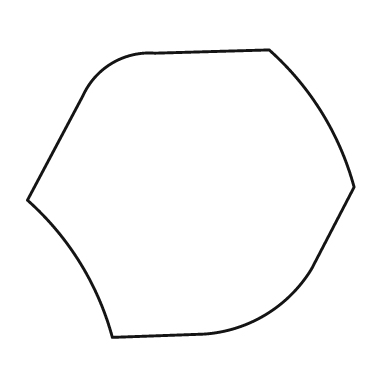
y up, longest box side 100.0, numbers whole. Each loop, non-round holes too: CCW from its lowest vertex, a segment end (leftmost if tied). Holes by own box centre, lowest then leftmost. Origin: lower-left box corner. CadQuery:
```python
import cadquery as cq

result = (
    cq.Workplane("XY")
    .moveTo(26.0, 0.0)
    .lineTo(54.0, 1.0)
    .threePointArc((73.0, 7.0), (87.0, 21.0))
    .lineTo(100.0, 46.0)
    .threePointArc((90.0, 69.0), (74.0, 88.0))
    .lineTo(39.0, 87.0)
    .threePointArc((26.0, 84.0), (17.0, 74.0))
    .lineTo(0.0, 42.0)
    .threePointArc((16.0, 23.0), (26.0, 0.0))
    .close()
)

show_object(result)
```